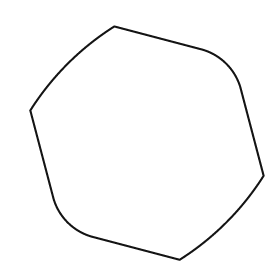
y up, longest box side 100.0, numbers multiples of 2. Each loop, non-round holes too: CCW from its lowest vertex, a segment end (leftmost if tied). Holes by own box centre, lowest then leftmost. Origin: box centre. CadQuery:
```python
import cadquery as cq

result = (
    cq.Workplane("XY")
    .moveTo(14.0, -50.0)
    .threePointArc((34.0, -34.0), (50.0, -14.0))
    .lineTo(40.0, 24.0)
    .threePointArc((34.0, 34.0), (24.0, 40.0))
    .lineTo(-14.0, 50.0)
    .threePointArc((-34.0, 34.0), (-50.0, 14.0))
    .lineTo(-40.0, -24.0)
    .threePointArc((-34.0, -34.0), (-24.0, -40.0))
    .close()
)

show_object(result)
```